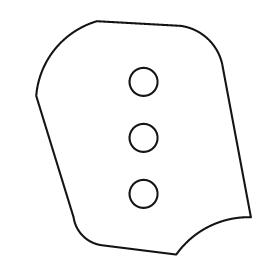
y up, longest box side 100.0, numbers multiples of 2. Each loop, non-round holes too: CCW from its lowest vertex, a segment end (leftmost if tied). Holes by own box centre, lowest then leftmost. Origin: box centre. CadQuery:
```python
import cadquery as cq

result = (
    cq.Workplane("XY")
    .moveTo(14.0, -50.0)
    .threePointArc((28.0, -38.0), (46.0, -34.0))
    .lineTo(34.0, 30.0)
    .threePointArc((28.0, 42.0), (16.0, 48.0))
    .lineTo(-20.0, 50.0)
    .threePointArc((-38.0, 38.0), (-46.0, 18.0))
    .lineTo(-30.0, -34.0)
    .threePointArc((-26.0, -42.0), (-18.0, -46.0))
    .close()
    .moveTo(0.0, -24.0)
    .circle(6.0)
    .moveTo(0.0, 0.0)
    .circle(6.0)
    .moveTo(0.0, 24.0)
    .circle(6.0)
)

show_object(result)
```